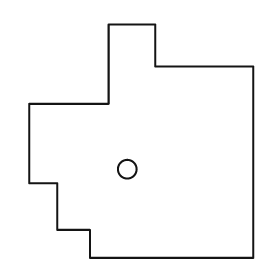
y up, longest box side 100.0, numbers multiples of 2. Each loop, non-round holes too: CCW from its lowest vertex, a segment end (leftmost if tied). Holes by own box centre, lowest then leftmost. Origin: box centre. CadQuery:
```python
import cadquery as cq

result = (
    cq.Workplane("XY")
    .moveTo(-22.0, -50.0)
    .lineTo(48.0, -50.0)
    .lineTo(48.0, 32.0)
    .lineTo(6.0, 32.0)
    .lineTo(6.0, 50.0)
    .lineTo(-14.0, 50.0)
    .lineTo(-14.0, 16.0)
    .lineTo(-48.0, 16.0)
    .lineTo(-48.0, -18.0)
    .lineTo(-36.0, -18.0)
    .lineTo(-36.0, -38.0)
    .lineTo(-22.0, -38.0)
    .close()
    .moveTo(-6.0, -12.0)
    .circle(4.0)
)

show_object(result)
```